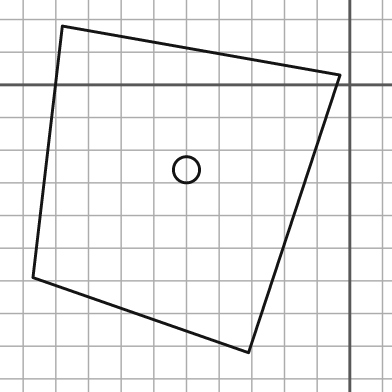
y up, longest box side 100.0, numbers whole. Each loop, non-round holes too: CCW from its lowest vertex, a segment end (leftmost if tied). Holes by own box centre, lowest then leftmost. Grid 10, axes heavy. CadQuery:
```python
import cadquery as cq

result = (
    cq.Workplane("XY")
    .moveTo(-31.0, -82.0)
    .lineTo(-3.0, 3.0)
    .lineTo(-88.0, 18.0)
    .lineTo(-97.0, -59.0)
    .close()
    .moveTo(-50.0, -26.0)
    .circle(4.0)
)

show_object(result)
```